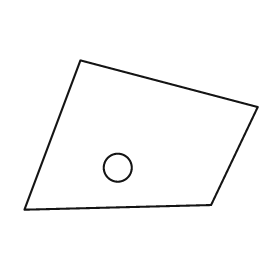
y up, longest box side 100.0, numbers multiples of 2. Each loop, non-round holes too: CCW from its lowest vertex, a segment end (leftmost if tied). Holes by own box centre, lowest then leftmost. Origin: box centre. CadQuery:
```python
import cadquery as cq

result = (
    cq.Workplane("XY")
    .moveTo(-50.0, -32.0)
    .lineTo(30.0, -30.0)
    .lineTo(50.0, 12.0)
    .lineTo(-26.0, 32.0)
    .close()
    .moveTo(-10.0, -14.0)
    .circle(6.0)
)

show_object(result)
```